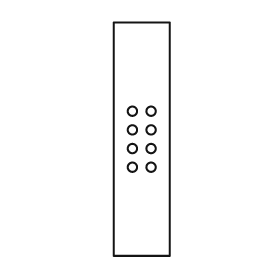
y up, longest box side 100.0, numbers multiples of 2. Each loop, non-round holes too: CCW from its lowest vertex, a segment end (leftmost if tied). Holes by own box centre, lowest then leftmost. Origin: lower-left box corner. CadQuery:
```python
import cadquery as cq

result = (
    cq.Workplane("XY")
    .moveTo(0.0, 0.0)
    .lineTo(24.0, 0.0)
    .lineTo(24.0, 100.0)
    .lineTo(0.0, 100.0)
    .close()
    .moveTo(8.0, 38.0)
    .circle(2.0)
    .moveTo(16.0, 38.0)
    .circle(2.0)
    .moveTo(8.0, 46.0)
    .circle(2.0)
    .moveTo(16.0, 46.0)
    .circle(2.0)
    .moveTo(8.0, 54.0)
    .circle(2.0)
    .moveTo(16.0, 54.0)
    .circle(2.0)
    .moveTo(8.0, 62.0)
    .circle(2.0)
    .moveTo(16.0, 62.0)
    .circle(2.0)
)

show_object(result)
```